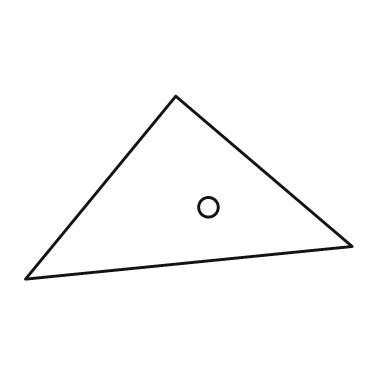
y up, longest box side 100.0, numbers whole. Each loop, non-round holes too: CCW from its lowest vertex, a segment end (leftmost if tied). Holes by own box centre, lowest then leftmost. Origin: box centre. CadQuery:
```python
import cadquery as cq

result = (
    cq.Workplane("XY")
    .moveTo(-50.0, -28.0)
    .lineTo(50.0, -18.0)
    .lineTo(-4.0, 28.0)
    .close()
    .moveTo(6.0, -6.0)
    .circle(3.0)
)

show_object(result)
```